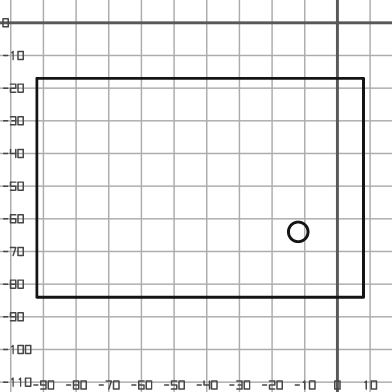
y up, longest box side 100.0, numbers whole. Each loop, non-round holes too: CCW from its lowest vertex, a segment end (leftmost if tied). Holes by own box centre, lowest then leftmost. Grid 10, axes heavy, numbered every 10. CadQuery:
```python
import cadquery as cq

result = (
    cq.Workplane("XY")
    .moveTo(-92.0, -84.0)
    .lineTo(8.0, -84.0)
    .lineTo(8.0, -17.0)
    .lineTo(-92.0, -17.0)
    .close()
    .moveTo(-12.0, -64.0)
    .circle(3.0)
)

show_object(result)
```